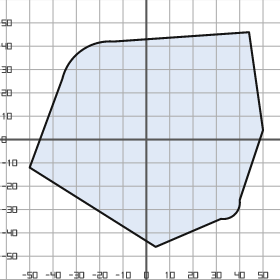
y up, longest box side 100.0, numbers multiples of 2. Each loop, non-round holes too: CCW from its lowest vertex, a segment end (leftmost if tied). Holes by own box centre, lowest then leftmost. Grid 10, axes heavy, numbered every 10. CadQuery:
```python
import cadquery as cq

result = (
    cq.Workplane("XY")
    .moveTo(4.0, -46.0)
    .lineTo(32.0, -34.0)
    .threePointArc((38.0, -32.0), (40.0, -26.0))
    .lineTo(50.0, 4.0)
    .lineTo(44.0, 46.0)
    .lineTo(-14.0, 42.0)
    .threePointArc((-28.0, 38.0), (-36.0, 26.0))
    .lineTo(-50.0, -12.0)
    .close()
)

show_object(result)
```